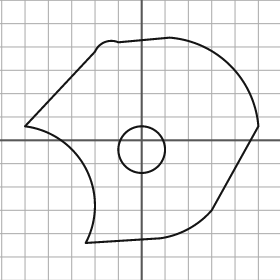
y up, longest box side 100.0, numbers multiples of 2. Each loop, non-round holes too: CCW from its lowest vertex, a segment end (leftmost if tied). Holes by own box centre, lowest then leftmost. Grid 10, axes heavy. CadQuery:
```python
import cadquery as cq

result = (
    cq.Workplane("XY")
    .moveTo(-24.0, -44.0)
    .lineTo(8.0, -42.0)
    .threePointArc((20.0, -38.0), (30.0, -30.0))
    .lineTo(50.0, 6.0)
    .threePointArc((38.0, 32.0), (12.0, 44.0))
    .lineTo(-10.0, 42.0)
    .threePointArc((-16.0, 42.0), (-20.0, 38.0))
    .lineTo(-50.0, 6.0)
    .threePointArc((-24.0, -12.0), (-24.0, -44.0))
    .close()
    .moveTo(0.0, -4.0)
    .circle(10.0)
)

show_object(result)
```